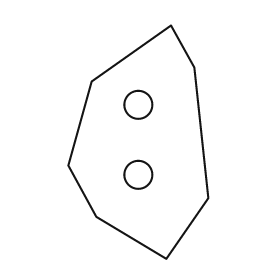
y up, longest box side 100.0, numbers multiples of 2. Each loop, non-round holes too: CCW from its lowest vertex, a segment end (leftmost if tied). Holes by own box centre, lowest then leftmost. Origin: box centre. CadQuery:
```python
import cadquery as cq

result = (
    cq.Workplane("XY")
    .moveTo(12.0, -50.0)
    .lineTo(30.0, -24.0)
    .lineTo(24.0, 32.0)
    .lineTo(14.0, 50.0)
    .lineTo(-20.0, 26.0)
    .lineTo(-30.0, -10.0)
    .lineTo(-18.0, -32.0)
    .close()
    .moveTo(0.0, -14.0)
    .circle(6.0)
    .moveTo(0.0, 16.0)
    .circle(6.0)
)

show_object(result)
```